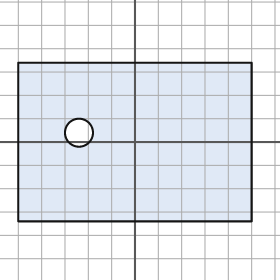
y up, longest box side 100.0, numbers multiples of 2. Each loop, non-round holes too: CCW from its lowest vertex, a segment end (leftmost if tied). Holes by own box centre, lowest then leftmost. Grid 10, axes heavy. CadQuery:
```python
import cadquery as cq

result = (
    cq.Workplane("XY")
    .moveTo(-50.0, -34.0)
    .lineTo(50.0, -34.0)
    .lineTo(50.0, 34.0)
    .lineTo(-50.0, 34.0)
    .close()
    .moveTo(-24.0, 4.0)
    .circle(6.0)
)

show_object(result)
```